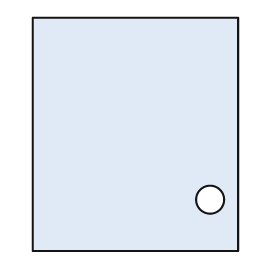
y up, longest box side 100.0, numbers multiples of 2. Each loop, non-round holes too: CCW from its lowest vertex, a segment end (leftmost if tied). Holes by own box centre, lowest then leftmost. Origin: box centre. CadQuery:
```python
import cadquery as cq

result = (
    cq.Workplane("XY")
    .moveTo(-44.0, -50.0)
    .lineTo(44.0, -50.0)
    .lineTo(44.0, 50.0)
    .lineTo(-44.0, 50.0)
    .close()
    .moveTo(32.0, -28.0)
    .circle(6.0)
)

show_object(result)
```